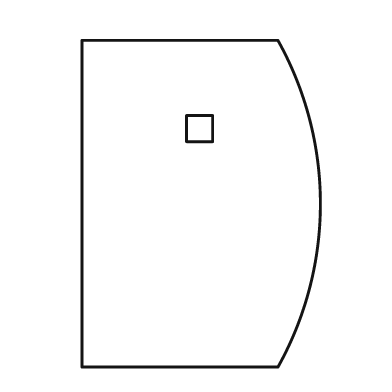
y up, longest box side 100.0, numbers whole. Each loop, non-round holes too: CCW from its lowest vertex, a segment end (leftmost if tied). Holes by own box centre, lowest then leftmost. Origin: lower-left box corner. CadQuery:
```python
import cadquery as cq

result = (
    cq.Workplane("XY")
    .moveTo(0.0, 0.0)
    .lineTo(60.0, 0.0)
    .threePointArc((73.0, 50.0), (60.0, 100.0))
    .lineTo(0.0, 100.0)
    .close()
    .moveTo(32.0, 69.0)
    .lineTo(40.0, 69.0)
    .lineTo(40.0, 77.0)
    .lineTo(32.0, 77.0)
    .close()
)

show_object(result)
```